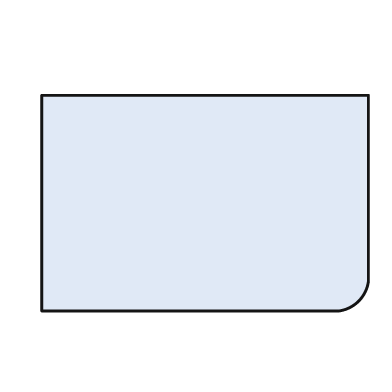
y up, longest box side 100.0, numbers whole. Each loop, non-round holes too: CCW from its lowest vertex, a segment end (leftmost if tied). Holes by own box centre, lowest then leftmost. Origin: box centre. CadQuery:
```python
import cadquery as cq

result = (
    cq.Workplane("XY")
    .moveTo(-50.0, -33.0)
    .lineTo(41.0, -33.0)
    .threePointArc((47.0, -30.0), (50.0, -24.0))
    .lineTo(50.0, 33.0)
    .lineTo(-50.0, 33.0)
    .close()
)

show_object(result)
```